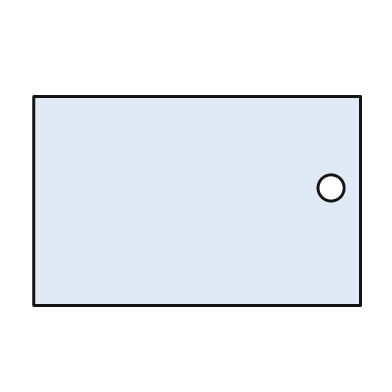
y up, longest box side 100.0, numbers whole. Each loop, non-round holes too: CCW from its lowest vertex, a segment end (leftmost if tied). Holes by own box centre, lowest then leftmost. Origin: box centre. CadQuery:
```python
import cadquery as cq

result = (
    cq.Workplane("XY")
    .moveTo(-50.0, -32.0)
    .lineTo(50.0, -32.0)
    .lineTo(50.0, 32.0)
    .lineTo(-50.0, 32.0)
    .close()
    .moveTo(41.0, 4.0)
    .circle(4.0)
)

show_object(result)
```